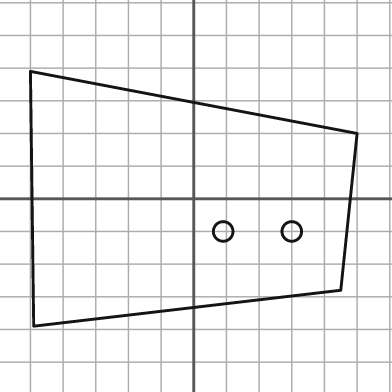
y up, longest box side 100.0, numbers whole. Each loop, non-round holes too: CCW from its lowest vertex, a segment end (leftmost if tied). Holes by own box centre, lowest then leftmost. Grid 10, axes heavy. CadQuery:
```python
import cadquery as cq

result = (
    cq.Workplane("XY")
    .moveTo(-49.0, -39.0)
    .lineTo(45.0, -28.0)
    .lineTo(50.0, 20.0)
    .lineTo(-50.0, 39.0)
    .close()
    .moveTo(9.0, -10.0)
    .circle(3.0)
    .moveTo(30.0, -10.0)
    .circle(3.0)
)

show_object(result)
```